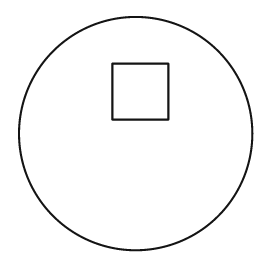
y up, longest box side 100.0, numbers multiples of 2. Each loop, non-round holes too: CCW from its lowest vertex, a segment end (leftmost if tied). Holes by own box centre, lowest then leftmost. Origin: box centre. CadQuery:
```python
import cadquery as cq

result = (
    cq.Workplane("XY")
    .moveTo(0.0, 0.0)
    .circle(50.0)
    .moveTo(-10.0, 6.0)
    .lineTo(14.0, 6.0)
    .lineTo(14.0, 30.0)
    .lineTo(-10.0, 30.0)
    .close()
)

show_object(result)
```